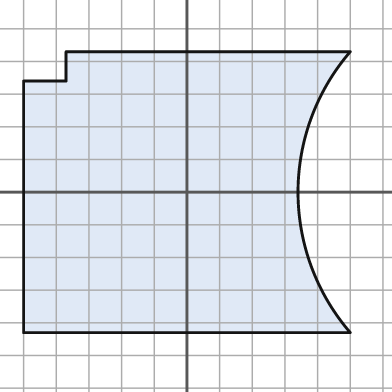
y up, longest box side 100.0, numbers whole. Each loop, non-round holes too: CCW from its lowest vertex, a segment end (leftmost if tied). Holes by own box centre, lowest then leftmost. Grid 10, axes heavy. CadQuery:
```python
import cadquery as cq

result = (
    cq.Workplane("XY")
    .moveTo(-50.0, -43.0)
    .lineTo(50.0, -43.0)
    .threePointArc((34.0, 0.0), (50.0, 43.0))
    .lineTo(-37.0, 43.0)
    .lineTo(-37.0, 34.0)
    .lineTo(-50.0, 34.0)
    .close()
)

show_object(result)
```